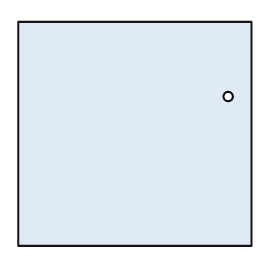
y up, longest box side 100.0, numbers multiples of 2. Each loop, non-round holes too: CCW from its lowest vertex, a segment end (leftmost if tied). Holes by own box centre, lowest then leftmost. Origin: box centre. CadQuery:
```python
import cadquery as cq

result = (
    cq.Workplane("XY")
    .moveTo(-50.0, -48.0)
    .lineTo(50.0, -48.0)
    .lineTo(50.0, 48.0)
    .lineTo(-50.0, 48.0)
    .close()
    .moveTo(40.0, 16.0)
    .circle(2.0)
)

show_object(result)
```